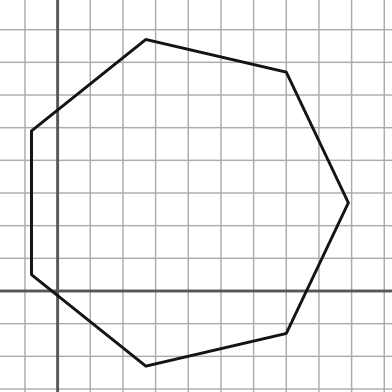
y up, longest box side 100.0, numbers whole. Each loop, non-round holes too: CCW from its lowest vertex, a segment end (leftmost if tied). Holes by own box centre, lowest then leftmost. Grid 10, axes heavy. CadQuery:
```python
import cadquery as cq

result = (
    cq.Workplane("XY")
    .moveTo(27.0, -23.0)
    .lineTo(70.0, -13.0)
    .lineTo(89.0, 27.0)
    .lineTo(70.0, 67.0)
    .lineTo(27.0, 77.0)
    .lineTo(-8.0, 49.0)
    .lineTo(-8.0, 5.0)
    .close()
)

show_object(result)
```